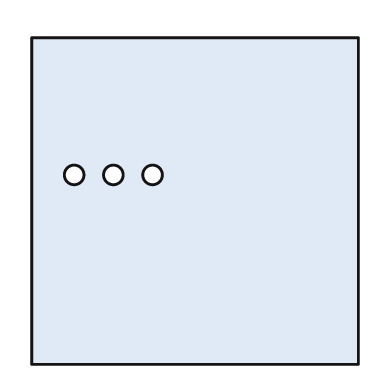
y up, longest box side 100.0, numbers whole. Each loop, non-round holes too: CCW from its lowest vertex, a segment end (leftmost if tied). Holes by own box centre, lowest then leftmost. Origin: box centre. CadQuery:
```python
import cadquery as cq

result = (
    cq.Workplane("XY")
    .moveTo(-50.0, -50.0)
    .lineTo(50.0, -50.0)
    .lineTo(50.0, 50.0)
    .lineTo(-50.0, 50.0)
    .close()
    .moveTo(-37.0, 8.0)
    .circle(3.0)
    .moveTo(-25.0, 8.0)
    .circle(3.0)
    .moveTo(-13.0, 8.0)
    .circle(3.0)
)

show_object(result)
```